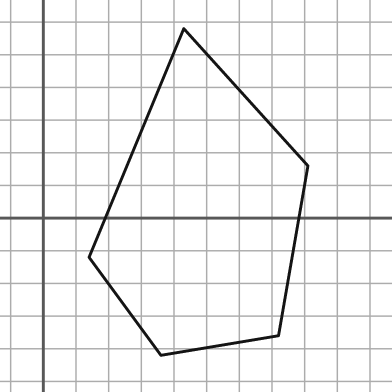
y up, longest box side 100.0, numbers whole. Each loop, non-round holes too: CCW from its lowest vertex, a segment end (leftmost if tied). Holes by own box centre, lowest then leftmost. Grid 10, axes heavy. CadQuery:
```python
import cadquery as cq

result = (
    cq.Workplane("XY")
    .moveTo(36.0, -42.0)
    .lineTo(72.0, -36.0)
    .lineTo(81.0, 16.0)
    .lineTo(43.0, 58.0)
    .lineTo(14.0, -12.0)
    .close()
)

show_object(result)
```